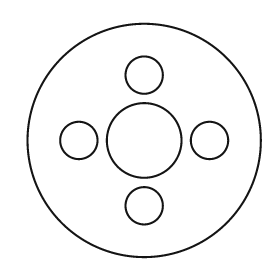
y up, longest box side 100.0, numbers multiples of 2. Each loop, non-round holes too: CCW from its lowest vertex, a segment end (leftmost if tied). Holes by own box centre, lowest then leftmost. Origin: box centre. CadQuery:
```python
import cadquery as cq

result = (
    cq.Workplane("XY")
    .moveTo(0.0, 0.0)
    .circle(50.0)
    .moveTo(0.0, -28.0)
    .circle(8.0)
    .moveTo(-28.0, 0.0)
    .circle(8.0)
    .moveTo(0.0, 0.0)
    .circle(16.0)
    .moveTo(28.0, 0.0)
    .circle(8.0)
    .moveTo(0.0, 28.0)
    .circle(8.0)
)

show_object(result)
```